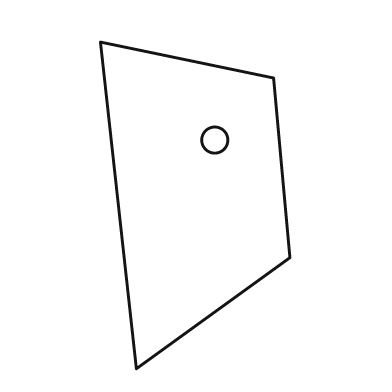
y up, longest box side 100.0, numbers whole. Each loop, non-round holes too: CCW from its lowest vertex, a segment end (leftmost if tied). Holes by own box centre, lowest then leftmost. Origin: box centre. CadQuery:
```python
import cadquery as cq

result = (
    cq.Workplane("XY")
    .moveTo(-18.0, -50.0)
    .lineTo(29.0, -16.0)
    .lineTo(24.0, 39.0)
    .lineTo(-29.0, 50.0)
    .close()
    .moveTo(6.0, 20.0)
    .circle(4.0)
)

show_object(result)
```